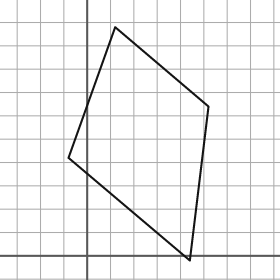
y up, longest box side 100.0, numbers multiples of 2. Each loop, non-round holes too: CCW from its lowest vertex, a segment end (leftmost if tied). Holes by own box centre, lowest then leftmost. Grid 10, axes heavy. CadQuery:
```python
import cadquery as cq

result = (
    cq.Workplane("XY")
    .moveTo(44.0, -2.0)
    .lineTo(52.0, 64.0)
    .lineTo(12.0, 98.0)
    .lineTo(-8.0, 42.0)
    .close()
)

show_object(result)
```